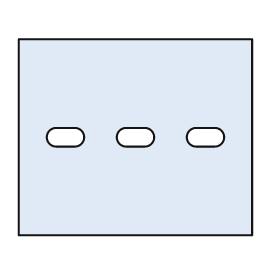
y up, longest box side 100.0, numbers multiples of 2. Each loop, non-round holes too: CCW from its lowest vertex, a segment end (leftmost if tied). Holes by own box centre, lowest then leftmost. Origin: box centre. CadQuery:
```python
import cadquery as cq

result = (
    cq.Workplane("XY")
    .moveTo(-50.0, -42.0)
    .lineTo(50.0, -42.0)
    .lineTo(50.0, 42.0)
    .lineTo(-50.0, 42.0)
    .close()
    .moveTo(-34.0, -4.0)
    .lineTo(-26.0, -4.0)
    .threePointArc((-22.0, 0.0), (-26.0, 4.0))
    .lineTo(-34.0, 4.0)
    .threePointArc((-38.0, 0.0), (-34.0, -4.0))
    .close()
    .moveTo(-4.0, -4.0)
    .lineTo(4.0, -4.0)
    .threePointArc((8.0, 0.0), (4.0, 4.0))
    .lineTo(-4.0, 4.0)
    .threePointArc((-8.0, 0.0), (-4.0, -4.0))
    .close()
    .moveTo(26.0, -4.0)
    .lineTo(34.0, -4.0)
    .threePointArc((38.0, 0.0), (34.0, 4.0))
    .lineTo(26.0, 4.0)
    .threePointArc((22.0, 0.0), (26.0, -4.0))
    .close()
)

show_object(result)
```